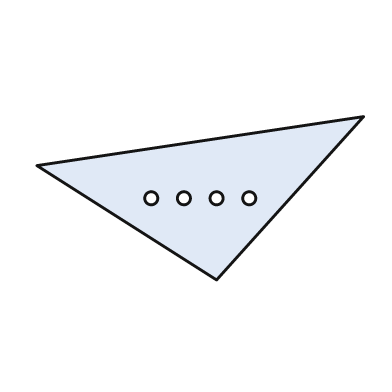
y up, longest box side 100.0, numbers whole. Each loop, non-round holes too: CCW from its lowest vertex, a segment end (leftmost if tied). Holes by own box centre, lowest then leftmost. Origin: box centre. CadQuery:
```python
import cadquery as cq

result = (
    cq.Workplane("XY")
    .moveTo(5.0, -25.0)
    .lineTo(50.0, 25.0)
    .lineTo(-50.0, 10.0)
    .close()
    .moveTo(-15.0, 0.0)
    .circle(2.0)
    .moveTo(-5.0, 0.0)
    .circle(2.0)
    .moveTo(5.0, 0.0)
    .circle(2.0)
    .moveTo(15.0, 0.0)
    .circle(2.0)
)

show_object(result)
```